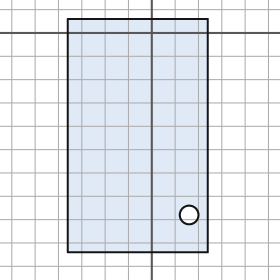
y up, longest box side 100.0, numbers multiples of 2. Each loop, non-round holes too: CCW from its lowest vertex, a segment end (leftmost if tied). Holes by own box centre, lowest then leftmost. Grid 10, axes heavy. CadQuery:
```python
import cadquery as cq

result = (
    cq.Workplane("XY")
    .moveTo(-36.0, -94.0)
    .lineTo(24.0, -94.0)
    .lineTo(24.0, 6.0)
    .lineTo(-36.0, 6.0)
    .close()
    .moveTo(16.0, -78.0)
    .circle(4.0)
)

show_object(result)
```